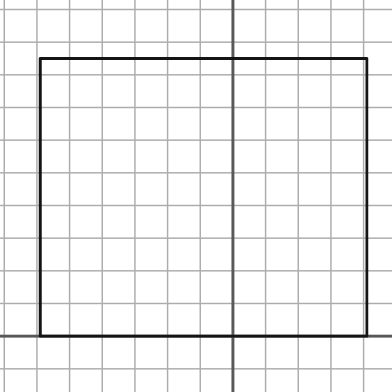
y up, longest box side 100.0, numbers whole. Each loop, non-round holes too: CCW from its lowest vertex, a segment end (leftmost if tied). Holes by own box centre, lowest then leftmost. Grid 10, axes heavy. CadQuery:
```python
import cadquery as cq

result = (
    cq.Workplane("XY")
    .moveTo(-59.0, 0.0)
    .lineTo(41.0, 0.0)
    .lineTo(41.0, 85.0)
    .lineTo(-59.0, 85.0)
    .close()
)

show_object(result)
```